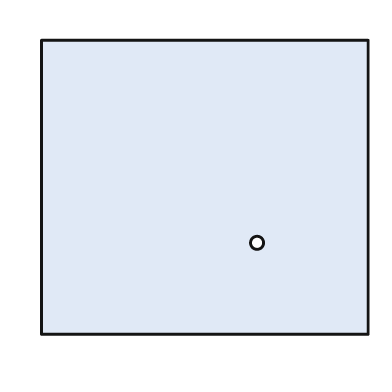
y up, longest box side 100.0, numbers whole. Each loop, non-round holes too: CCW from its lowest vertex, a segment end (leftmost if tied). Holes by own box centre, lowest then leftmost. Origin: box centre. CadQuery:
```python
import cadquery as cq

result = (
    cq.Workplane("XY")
    .moveTo(-50.0, -45.0)
    .lineTo(50.0, -45.0)
    .lineTo(50.0, 45.0)
    .lineTo(-50.0, 45.0)
    .close()
    .moveTo(16.0, -17.0)
    .circle(2.0)
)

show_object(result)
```